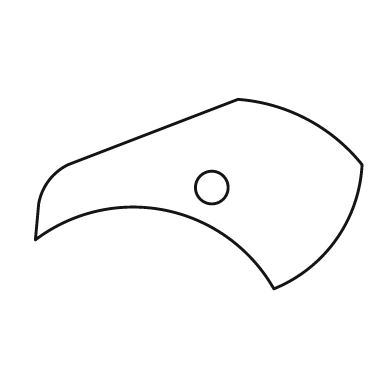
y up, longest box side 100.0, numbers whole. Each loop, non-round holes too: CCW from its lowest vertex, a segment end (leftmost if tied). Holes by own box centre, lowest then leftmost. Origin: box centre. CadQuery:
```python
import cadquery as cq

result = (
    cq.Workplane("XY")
    .moveTo(23.0, -29.0)
    .threePointArc((42.0, -14.0), (50.0, 9.0))
    .threePointArc((33.0, 23.0), (12.0, 29.0))
    .lineTo(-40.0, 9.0)
    .threePointArc((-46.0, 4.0), (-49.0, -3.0))
    .lineTo(-50.0, -14.0)
    .threePointArc((-10.0, -5.0), (23.0, -29.0))
    .close()
    .moveTo(4.0, 2.0)
    .circle(5.0)
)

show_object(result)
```